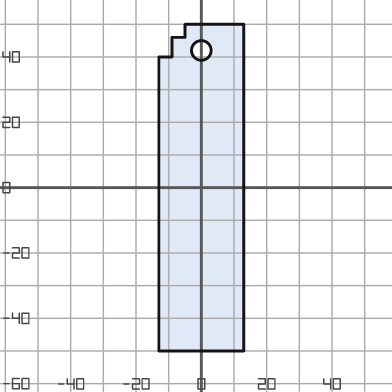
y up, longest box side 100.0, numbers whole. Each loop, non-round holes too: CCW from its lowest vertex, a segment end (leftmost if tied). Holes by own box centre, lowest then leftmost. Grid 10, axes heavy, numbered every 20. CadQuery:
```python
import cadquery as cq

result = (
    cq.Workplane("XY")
    .moveTo(-13.0, -50.0)
    .lineTo(13.0, -50.0)
    .lineTo(13.0, 50.0)
    .lineTo(-5.0, 50.0)
    .lineTo(-5.0, 46.0)
    .lineTo(-9.0, 46.0)
    .lineTo(-9.0, 40.0)
    .lineTo(-13.0, 40.0)
    .close()
    .moveTo(0.0, 42.0)
    .circle(3.0)
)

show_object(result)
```